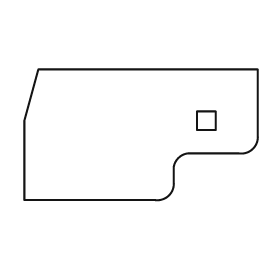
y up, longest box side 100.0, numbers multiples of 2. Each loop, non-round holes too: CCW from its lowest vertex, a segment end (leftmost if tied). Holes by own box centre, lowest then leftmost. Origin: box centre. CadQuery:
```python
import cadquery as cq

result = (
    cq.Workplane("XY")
    .moveTo(-50.0, -28.0)
    .lineTo(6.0, -28.0)
    .threePointArc((12.0, -26.0), (14.0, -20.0))
    .lineTo(14.0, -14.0)
    .threePointArc((16.0, -10.0), (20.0, -8.0))
    .lineTo(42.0, -8.0)
    .threePointArc((48.0, -6.0), (50.0, 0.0))
    .lineTo(50.0, 28.0)
    .lineTo(-44.0, 28.0)
    .lineTo(-50.0, 6.0)
    .close()
    .moveTo(24.0, 2.0)
    .lineTo(32.0, 2.0)
    .lineTo(32.0, 10.0)
    .lineTo(24.0, 10.0)
    .close()
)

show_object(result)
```